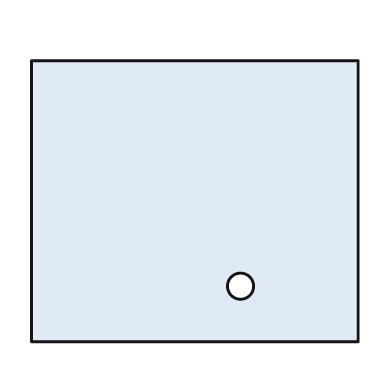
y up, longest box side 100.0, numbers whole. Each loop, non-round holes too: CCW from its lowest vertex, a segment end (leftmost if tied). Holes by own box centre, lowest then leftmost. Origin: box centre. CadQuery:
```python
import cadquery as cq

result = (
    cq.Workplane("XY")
    .moveTo(-50.0, -43.0)
    .lineTo(50.0, -43.0)
    .lineTo(50.0, 43.0)
    .lineTo(-50.0, 43.0)
    .close()
    .moveTo(14.0, -26.0)
    .circle(4.0)
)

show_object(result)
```